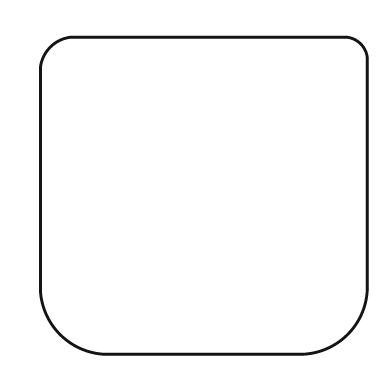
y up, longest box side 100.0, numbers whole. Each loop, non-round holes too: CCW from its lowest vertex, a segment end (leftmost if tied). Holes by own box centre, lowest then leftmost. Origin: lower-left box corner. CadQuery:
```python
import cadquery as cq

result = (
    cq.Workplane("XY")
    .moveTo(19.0, 0.0)
    .lineTo(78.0, 0.0)
    .threePointArc((94.0, 6.0), (100.0, 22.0))
    .lineTo(100.0, 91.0)
    .threePointArc((98.0, 95.0), (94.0, 97.0))
    .lineTo(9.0, 97.0)
    .threePointArc((3.0, 94.0), (0.0, 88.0))
    .lineTo(0.0, 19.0)
    .threePointArc((6.0, 6.0), (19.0, 0.0))
    .close()
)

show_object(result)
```